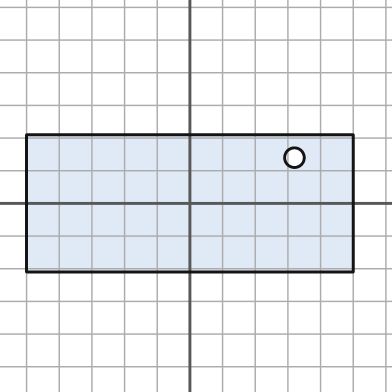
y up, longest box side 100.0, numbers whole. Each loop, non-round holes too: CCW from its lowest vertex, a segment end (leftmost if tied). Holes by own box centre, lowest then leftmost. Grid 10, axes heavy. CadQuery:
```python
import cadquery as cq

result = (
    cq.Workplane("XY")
    .moveTo(-50.0, -21.0)
    .lineTo(50.0, -21.0)
    .lineTo(50.0, 21.0)
    .lineTo(-50.0, 21.0)
    .close()
    .moveTo(32.0, 14.0)
    .circle(3.0)
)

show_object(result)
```